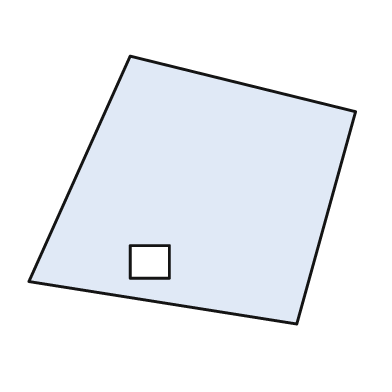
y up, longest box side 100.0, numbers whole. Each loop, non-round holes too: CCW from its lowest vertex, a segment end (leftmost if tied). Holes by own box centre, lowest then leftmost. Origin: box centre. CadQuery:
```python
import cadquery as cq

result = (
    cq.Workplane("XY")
    .moveTo(32.0, -41.0)
    .lineTo(50.0, 24.0)
    .lineTo(-19.0, 41.0)
    .lineTo(-50.0, -28.0)
    .close()
    .moveTo(-19.0, -27.0)
    .lineTo(-7.0, -27.0)
    .lineTo(-7.0, -17.0)
    .lineTo(-19.0, -17.0)
    .close()
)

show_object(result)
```